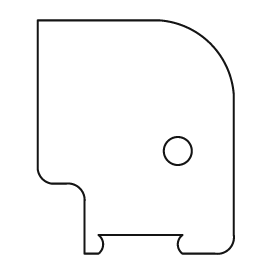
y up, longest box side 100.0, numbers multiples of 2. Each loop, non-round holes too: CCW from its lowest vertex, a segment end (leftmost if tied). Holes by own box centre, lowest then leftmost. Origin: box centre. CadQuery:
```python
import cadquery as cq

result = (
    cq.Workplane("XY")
    .moveTo(-22.0, -50.0)
    .lineTo(-16.0, -50.0)
    .threePointArc((-14.0, -46.0), (-16.0, -42.0))
    .lineTo(20.0, -42.0)
    .threePointArc((18.0, -46.0), (20.0, -50.0))
    .lineTo(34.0, -50.0)
    .threePointArc((40.0, -48.0), (42.0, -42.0))
    .lineTo(42.0, 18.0)
    .threePointArc((32.0, 40.0), (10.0, 50.0))
    .lineTo(-42.0, 50.0)
    .lineTo(-42.0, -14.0)
    .threePointArc((-40.0, -18.0), (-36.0, -20.0))
    .lineTo(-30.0, -20.0)
    .threePointArc((-24.0, -22.0), (-22.0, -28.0))
    .close()
    .moveTo(18.0, -6.0)
    .circle(6.0)
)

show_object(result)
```